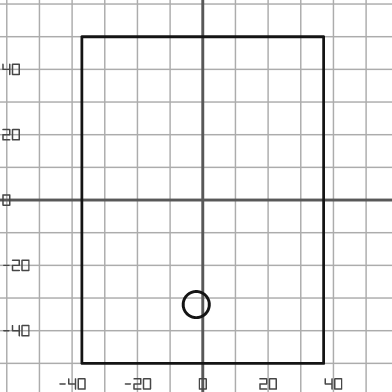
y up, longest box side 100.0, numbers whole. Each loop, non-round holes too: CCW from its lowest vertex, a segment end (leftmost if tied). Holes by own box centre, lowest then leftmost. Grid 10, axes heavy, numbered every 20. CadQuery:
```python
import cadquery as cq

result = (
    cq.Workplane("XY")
    .moveTo(-37.0, -50.0)
    .lineTo(37.0, -50.0)
    .lineTo(37.0, 50.0)
    .lineTo(-37.0, 50.0)
    .close()
    .moveTo(-2.0, -32.0)
    .circle(4.0)
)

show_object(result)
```